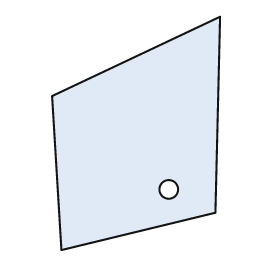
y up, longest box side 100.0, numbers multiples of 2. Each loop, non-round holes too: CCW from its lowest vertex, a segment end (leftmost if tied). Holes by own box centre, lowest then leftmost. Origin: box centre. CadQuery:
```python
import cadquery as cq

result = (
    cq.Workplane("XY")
    .moveTo(-32.0, -50.0)
    .lineTo(34.0, -34.0)
    .lineTo(36.0, 50.0)
    .lineTo(-36.0, 16.0)
    .close()
    .moveTo(14.0, -24.0)
    .circle(4.0)
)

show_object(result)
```